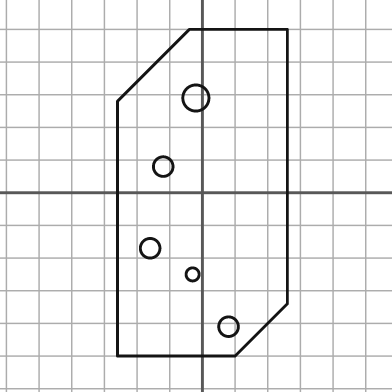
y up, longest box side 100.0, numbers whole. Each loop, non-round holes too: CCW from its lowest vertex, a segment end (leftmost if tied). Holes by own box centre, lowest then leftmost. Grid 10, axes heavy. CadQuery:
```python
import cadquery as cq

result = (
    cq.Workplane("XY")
    .moveTo(-26.0, -50.0)
    .lineTo(10.0, -50.0)
    .lineTo(26.0, -34.0)
    .lineTo(26.0, 50.0)
    .lineTo(-4.0, 50.0)
    .lineTo(-26.0, 28.0)
    .close()
    .moveTo(8.0, -41.0)
    .circle(3.0)
    .moveTo(-3.0, -25.0)
    .circle(2.0)
    .moveTo(-16.0, -17.0)
    .circle(3.0)
    .moveTo(-12.0, 8.0)
    .circle(3.0)
    .moveTo(-2.0, 29.0)
    .circle(4.0)
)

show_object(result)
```